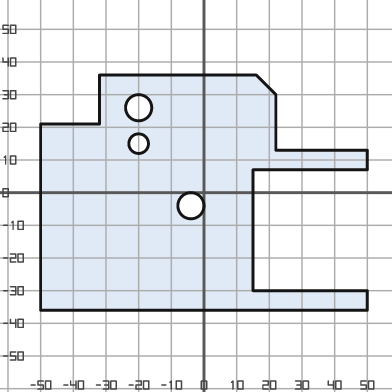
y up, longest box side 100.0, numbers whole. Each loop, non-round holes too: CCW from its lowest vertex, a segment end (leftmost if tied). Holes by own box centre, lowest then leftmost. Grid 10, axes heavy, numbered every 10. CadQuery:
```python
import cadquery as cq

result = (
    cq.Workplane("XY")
    .moveTo(-50.0, -36.0)
    .lineTo(50.0, -36.0)
    .lineTo(50.0, -30.0)
    .lineTo(15.0, -30.0)
    .lineTo(15.0, 7.0)
    .lineTo(50.0, 7.0)
    .lineTo(50.0, 13.0)
    .lineTo(22.0, 13.0)
    .lineTo(22.0, 30.0)
    .lineTo(16.0, 36.0)
    .lineTo(-32.0, 36.0)
    .lineTo(-32.0, 21.0)
    .lineTo(-50.0, 21.0)
    .close()
    .moveTo(-4.0, -4.0)
    .circle(4.0)
    .moveTo(-20.0, 15.0)
    .circle(3.0)
    .moveTo(-20.0, 26.0)
    .circle(4.0)
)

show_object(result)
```